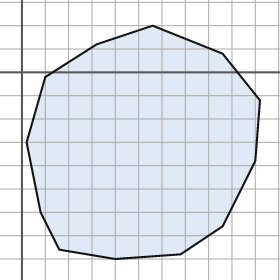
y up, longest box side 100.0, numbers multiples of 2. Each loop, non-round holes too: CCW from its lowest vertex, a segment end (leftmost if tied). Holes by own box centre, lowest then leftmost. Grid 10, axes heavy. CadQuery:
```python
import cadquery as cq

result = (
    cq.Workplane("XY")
    .moveTo(40.0, -80.0)
    .lineTo(68.0, -78.0)
    .lineTo(86.0, -66.0)
    .lineTo(100.0, -38.0)
    .lineTo(102.0, -12.0)
    .lineTo(86.0, 8.0)
    .lineTo(56.0, 20.0)
    .lineTo(32.0, 12.0)
    .lineTo(10.0, -2.0)
    .lineTo(2.0, -30.0)
    .lineTo(8.0, -60.0)
    .lineTo(16.0, -76.0)
    .close()
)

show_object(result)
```